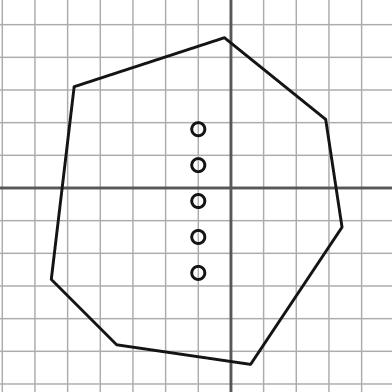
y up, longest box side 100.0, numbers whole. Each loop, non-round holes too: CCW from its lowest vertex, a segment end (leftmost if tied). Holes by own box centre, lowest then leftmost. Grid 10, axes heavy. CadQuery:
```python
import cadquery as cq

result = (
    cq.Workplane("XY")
    .moveTo(6.0, -54.0)
    .lineTo(34.0, -12.0)
    .lineTo(29.0, 21.0)
    .lineTo(-2.0, 46.0)
    .lineTo(-48.0, 31.0)
    .lineTo(-55.0, -28.0)
    .lineTo(-35.0, -48.0)
    .close()
    .moveTo(-10.0, -26.0)
    .circle(2.0)
    .moveTo(-10.0, -15.0)
    .circle(2.0)
    .moveTo(-10.0, -4.0)
    .circle(2.0)
    .moveTo(-10.0, 7.0)
    .circle(2.0)
    .moveTo(-10.0, 18.0)
    .circle(2.0)
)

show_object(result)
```